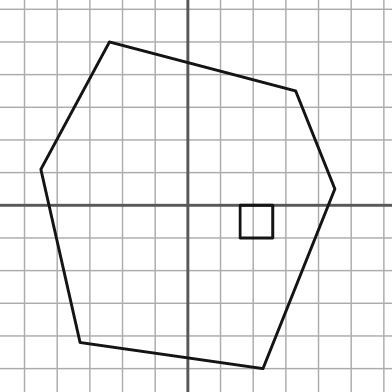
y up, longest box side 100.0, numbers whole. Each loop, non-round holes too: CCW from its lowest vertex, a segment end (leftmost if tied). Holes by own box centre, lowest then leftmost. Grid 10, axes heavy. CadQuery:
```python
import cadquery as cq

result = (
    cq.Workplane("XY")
    .moveTo(23.0, -50.0)
    .lineTo(45.0, 5.0)
    .lineTo(33.0, 35.0)
    .lineTo(-24.0, 50.0)
    .lineTo(-45.0, 11.0)
    .lineTo(-33.0, -42.0)
    .close()
    .moveTo(16.0, -10.0)
    .lineTo(26.0, -10.0)
    .lineTo(26.0, 0.0)
    .lineTo(16.0, 0.0)
    .close()
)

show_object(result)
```